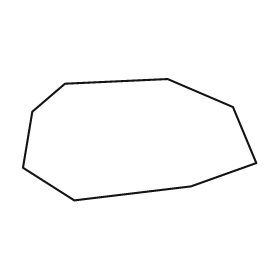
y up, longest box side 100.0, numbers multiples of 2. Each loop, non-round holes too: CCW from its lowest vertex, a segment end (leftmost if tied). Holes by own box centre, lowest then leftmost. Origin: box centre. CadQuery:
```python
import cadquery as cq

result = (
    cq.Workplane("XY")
    .moveTo(-28.0, -26.0)
    .lineTo(22.0, -20.0)
    .lineTo(50.0, -10.0)
    .lineTo(40.0, 14.0)
    .lineTo(12.0, 26.0)
    .lineTo(-32.0, 24.0)
    .lineTo(-46.0, 12.0)
    .lineTo(-50.0, -12.0)
    .close()
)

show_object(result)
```